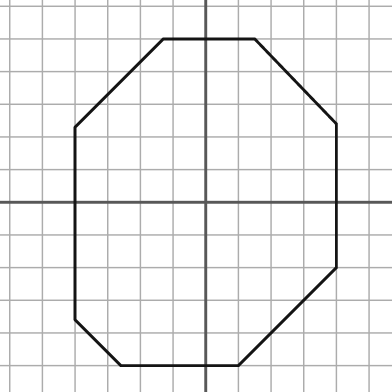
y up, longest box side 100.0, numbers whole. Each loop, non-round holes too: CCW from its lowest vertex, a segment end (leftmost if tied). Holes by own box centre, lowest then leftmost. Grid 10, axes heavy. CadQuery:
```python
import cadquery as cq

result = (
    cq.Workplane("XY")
    .moveTo(-26.0, -50.0)
    .lineTo(10.0, -50.0)
    .lineTo(40.0, -20.0)
    .lineTo(40.0, 24.0)
    .lineTo(15.0, 50.0)
    .lineTo(-13.0, 50.0)
    .lineTo(-40.0, 23.0)
    .lineTo(-40.0, -36.0)
    .close()
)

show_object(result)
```